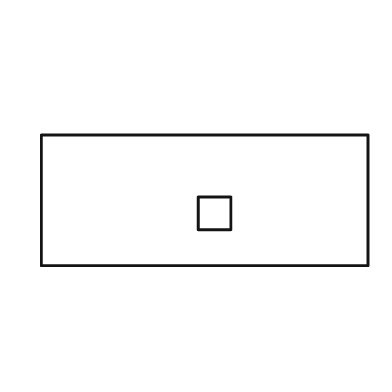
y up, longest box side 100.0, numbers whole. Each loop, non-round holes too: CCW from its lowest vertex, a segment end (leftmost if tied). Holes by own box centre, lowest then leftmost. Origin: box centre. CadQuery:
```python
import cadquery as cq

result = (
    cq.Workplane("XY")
    .moveTo(-50.0, -20.0)
    .lineTo(50.0, -20.0)
    .lineTo(50.0, 20.0)
    .lineTo(-50.0, 20.0)
    .close()
    .moveTo(-2.0, -9.0)
    .lineTo(8.0, -9.0)
    .lineTo(8.0, 1.0)
    .lineTo(-2.0, 1.0)
    .close()
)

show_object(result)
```